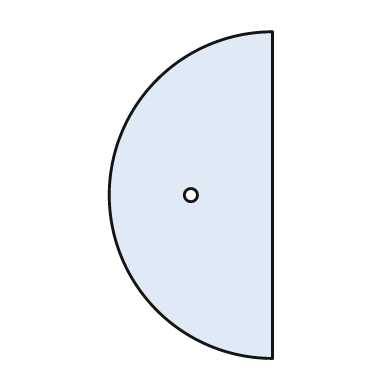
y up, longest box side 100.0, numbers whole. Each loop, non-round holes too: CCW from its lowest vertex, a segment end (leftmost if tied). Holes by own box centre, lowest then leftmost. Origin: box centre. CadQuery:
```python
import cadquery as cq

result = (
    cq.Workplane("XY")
    .moveTo(25.0, -50.0)
    .lineTo(25.0, 50.0)
    .threePointArc((-25.0, 0.0), (25.0, -50.0))
    .close()
    .moveTo(0.0, 0.0)
    .circle(2.0)
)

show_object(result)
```